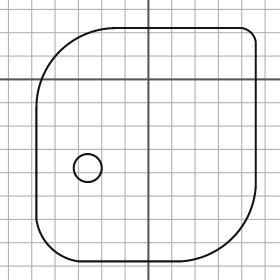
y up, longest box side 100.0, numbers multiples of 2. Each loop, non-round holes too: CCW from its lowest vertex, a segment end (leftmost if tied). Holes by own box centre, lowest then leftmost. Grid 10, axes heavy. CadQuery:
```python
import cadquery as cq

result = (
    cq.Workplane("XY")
    .moveTo(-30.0, -78.0)
    .lineTo(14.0, -78.0)
    .threePointArc((36.0, -68.0), (46.0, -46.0))
    .lineTo(46.0, 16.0)
    .threePointArc((44.0, 20.0), (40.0, 22.0))
    .lineTo(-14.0, 22.0)
    .threePointArc((-38.0, 12.0), (-48.0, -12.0))
    .lineTo(-48.0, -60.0)
    .threePointArc((-42.0, -72.0), (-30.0, -78.0))
    .close()
    .moveTo(-26.0, -38.0)
    .circle(6.0)
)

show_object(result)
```